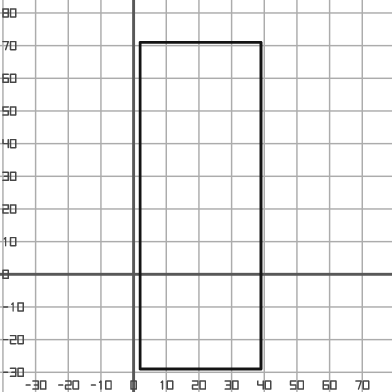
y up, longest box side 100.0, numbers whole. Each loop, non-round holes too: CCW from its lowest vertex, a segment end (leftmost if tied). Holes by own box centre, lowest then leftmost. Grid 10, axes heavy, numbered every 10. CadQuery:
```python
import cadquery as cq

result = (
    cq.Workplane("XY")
    .moveTo(2.0, -29.0)
    .lineTo(39.0, -29.0)
    .lineTo(39.0, 71.0)
    .lineTo(2.0, 71.0)
    .close()
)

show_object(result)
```